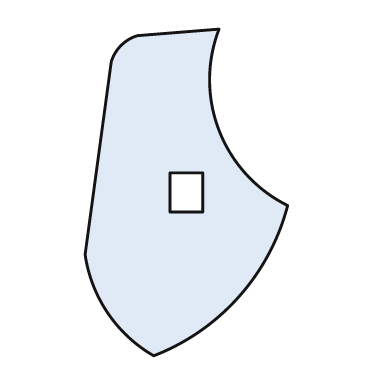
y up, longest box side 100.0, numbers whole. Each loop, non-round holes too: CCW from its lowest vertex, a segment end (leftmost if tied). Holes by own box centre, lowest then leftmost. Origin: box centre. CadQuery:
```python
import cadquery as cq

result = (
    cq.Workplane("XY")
    .moveTo(-10.0, -50.0)
    .threePointArc((16.0, -32.0), (31.0, -4.0))
    .threePointArc((10.0, 19.0), (10.0, 50.0))
    .lineTo(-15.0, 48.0)
    .threePointArc((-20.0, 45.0), (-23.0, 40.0))
    .lineTo(-31.0, -19.0)
    .threePointArc((-24.0, -37.0), (-10.0, -50.0))
    .close()
    .moveTo(-5.0, -6.0)
    .lineTo(5.0, -6.0)
    .lineTo(5.0, 6.0)
    .lineTo(-5.0, 6.0)
    .close()
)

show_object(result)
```